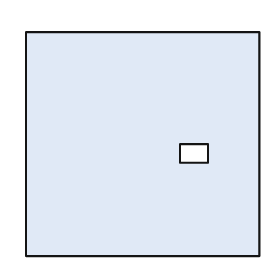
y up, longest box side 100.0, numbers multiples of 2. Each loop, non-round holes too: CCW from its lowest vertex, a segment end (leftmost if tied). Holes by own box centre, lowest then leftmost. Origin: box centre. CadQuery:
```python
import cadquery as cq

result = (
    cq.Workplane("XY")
    .moveTo(-50.0, -48.0)
    .lineTo(50.0, -48.0)
    .lineTo(50.0, 48.0)
    .lineTo(-50.0, 48.0)
    .close()
    .moveTo(16.0, -8.0)
    .lineTo(28.0, -8.0)
    .lineTo(28.0, 0.0)
    .lineTo(16.0, 0.0)
    .close()
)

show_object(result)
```